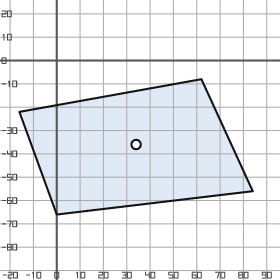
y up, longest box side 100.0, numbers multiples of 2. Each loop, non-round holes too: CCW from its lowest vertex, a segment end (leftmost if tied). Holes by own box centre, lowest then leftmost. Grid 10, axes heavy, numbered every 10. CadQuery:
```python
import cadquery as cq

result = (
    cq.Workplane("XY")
    .moveTo(0.0, -66.0)
    .lineTo(84.0, -56.0)
    .lineTo(62.0, -8.0)
    .lineTo(-16.0, -22.0)
    .close()
    .moveTo(34.0, -36.0)
    .circle(2.0)
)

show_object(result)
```